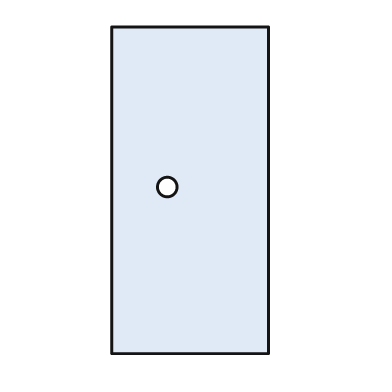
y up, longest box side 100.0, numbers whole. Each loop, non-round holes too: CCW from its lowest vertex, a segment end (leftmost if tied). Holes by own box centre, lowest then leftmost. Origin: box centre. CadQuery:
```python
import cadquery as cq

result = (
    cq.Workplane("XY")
    .moveTo(-24.0, -50.0)
    .lineTo(24.0, -50.0)
    .lineTo(24.0, 50.0)
    .lineTo(-24.0, 50.0)
    .close()
    .moveTo(-7.0, 1.0)
    .circle(3.0)
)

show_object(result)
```